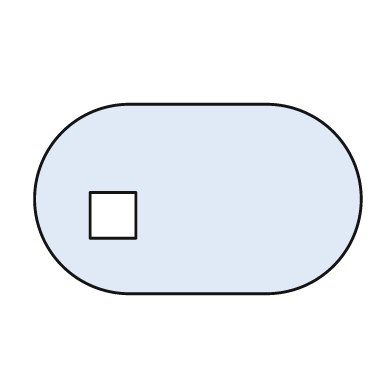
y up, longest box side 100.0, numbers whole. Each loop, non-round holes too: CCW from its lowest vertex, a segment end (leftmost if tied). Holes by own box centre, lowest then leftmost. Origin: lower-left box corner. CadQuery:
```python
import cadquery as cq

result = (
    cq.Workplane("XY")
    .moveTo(29.0, 0.0)
    .lineTo(71.0, 0.0)
    .threePointArc((100.0, 29.0), (71.0, 58.0))
    .lineTo(29.0, 58.0)
    .threePointArc((0.0, 29.0), (29.0, 0.0))
    .close()
    .moveTo(17.0, 17.0)
    .lineTo(31.0, 17.0)
    .lineTo(31.0, 31.0)
    .lineTo(17.0, 31.0)
    .close()
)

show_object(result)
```